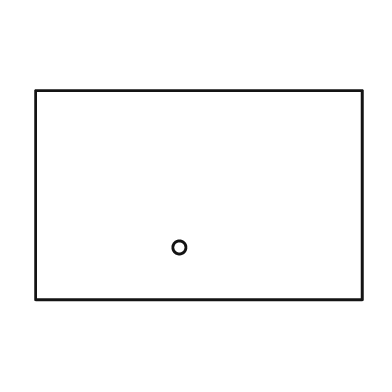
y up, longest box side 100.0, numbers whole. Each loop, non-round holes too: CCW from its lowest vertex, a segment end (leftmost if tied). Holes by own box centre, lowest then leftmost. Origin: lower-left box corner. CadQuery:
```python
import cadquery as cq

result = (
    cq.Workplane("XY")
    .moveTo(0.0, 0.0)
    .lineTo(100.0, 0.0)
    .lineTo(100.0, 64.0)
    .lineTo(0.0, 64.0)
    .close()
    .moveTo(44.0, 16.0)
    .circle(2.0)
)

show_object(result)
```